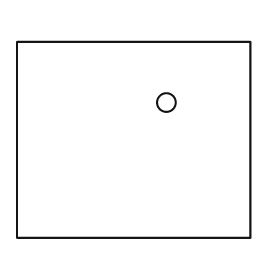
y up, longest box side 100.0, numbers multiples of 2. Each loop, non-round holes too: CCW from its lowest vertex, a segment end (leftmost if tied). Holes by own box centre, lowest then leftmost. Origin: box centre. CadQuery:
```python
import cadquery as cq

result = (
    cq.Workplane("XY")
    .moveTo(-50.0, -42.0)
    .lineTo(50.0, -42.0)
    .lineTo(50.0, 42.0)
    .lineTo(-50.0, 42.0)
    .close()
    .moveTo(14.0, 16.0)
    .circle(4.0)
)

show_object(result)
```